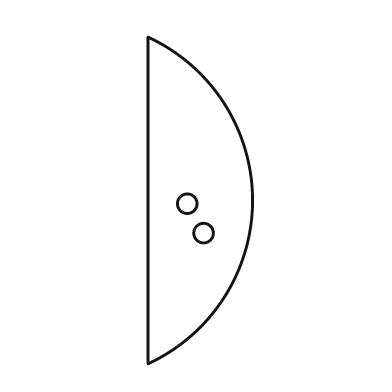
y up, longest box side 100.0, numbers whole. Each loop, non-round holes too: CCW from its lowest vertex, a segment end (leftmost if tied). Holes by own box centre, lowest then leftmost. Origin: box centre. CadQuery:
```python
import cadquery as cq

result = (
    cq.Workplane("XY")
    .moveTo(-16.0, -50.0)
    .threePointArc((16.0, 0.0), (-16.0, 50.0))
    .close()
    .moveTo(1.0, -10.0)
    .circle(3.0)
    .moveTo(-4.0, -1.0)
    .circle(3.0)
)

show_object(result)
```